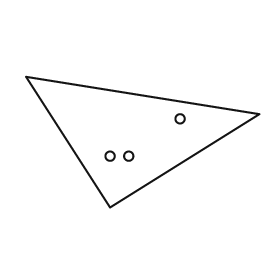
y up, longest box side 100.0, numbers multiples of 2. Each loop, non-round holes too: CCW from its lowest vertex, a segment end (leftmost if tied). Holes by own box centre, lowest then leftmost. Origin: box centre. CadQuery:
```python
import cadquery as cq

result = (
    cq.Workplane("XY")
    .moveTo(-14.0, -28.0)
    .lineTo(50.0, 12.0)
    .lineTo(-50.0, 28.0)
    .close()
    .moveTo(-14.0, -6.0)
    .circle(2.0)
    .moveTo(-6.0, -6.0)
    .circle(2.0)
    .moveTo(16.0, 10.0)
    .circle(2.0)
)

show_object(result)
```